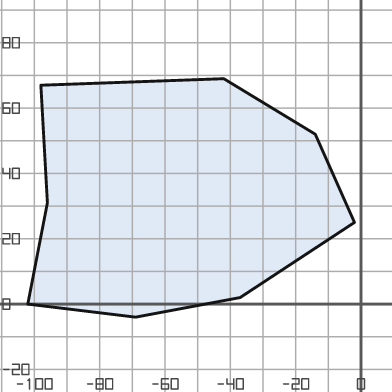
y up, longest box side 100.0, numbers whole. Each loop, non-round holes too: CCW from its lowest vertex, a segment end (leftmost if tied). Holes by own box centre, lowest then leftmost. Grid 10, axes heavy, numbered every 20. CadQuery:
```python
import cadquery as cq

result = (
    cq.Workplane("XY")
    .moveTo(-69.0, -4.0)
    .lineTo(-37.0, 2.0)
    .lineTo(-2.0, 25.0)
    .lineTo(-14.0, 52.0)
    .lineTo(-42.0, 69.0)
    .lineTo(-98.0, 67.0)
    .lineTo(-96.0, 31.0)
    .lineTo(-102.0, 0.0)
    .close()
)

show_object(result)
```